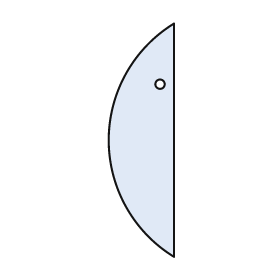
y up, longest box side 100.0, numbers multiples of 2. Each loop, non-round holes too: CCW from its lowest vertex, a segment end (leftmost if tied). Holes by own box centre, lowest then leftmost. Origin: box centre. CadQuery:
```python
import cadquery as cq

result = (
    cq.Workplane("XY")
    .moveTo(14.0, -50.0)
    .lineTo(14.0, 50.0)
    .threePointArc((-14.0, 0.0), (14.0, -50.0))
    .close()
    .moveTo(8.0, 24.0)
    .circle(2.0)
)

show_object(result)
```